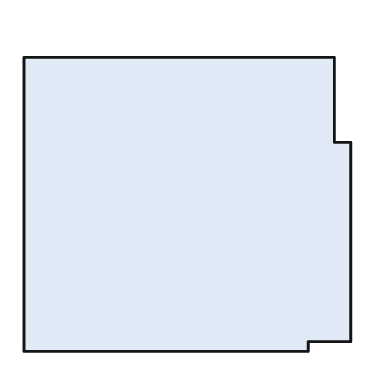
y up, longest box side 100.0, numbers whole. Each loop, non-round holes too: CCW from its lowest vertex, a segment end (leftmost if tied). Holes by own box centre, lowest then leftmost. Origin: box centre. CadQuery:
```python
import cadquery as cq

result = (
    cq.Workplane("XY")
    .moveTo(-50.0, -45.0)
    .lineTo(37.0, -45.0)
    .lineTo(37.0, -42.0)
    .lineTo(50.0, -42.0)
    .lineTo(50.0, 19.0)
    .lineTo(45.0, 19.0)
    .lineTo(45.0, 45.0)
    .lineTo(-50.0, 45.0)
    .close()
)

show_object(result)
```